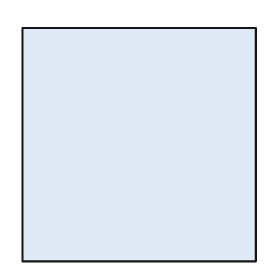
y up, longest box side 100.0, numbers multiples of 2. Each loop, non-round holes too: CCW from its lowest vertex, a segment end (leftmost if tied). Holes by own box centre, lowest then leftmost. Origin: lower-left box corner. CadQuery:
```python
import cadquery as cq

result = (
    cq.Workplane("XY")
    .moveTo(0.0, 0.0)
    .lineTo(100.0, 0.0)
    .lineTo(100.0, 100.0)
    .lineTo(0.0, 100.0)
    .close()
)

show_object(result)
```